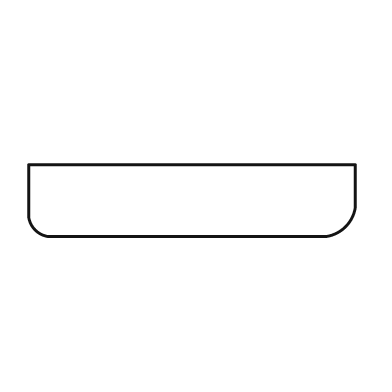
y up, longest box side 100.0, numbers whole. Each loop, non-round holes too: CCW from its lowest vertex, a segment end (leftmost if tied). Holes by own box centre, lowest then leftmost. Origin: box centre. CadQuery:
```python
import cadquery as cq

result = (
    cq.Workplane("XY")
    .moveTo(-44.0, -11.0)
    .lineTo(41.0, -11.0)
    .threePointArc((47.0, -8.0), (50.0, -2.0))
    .lineTo(50.0, 11.0)
    .lineTo(-50.0, 11.0)
    .lineTo(-50.0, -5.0)
    .threePointArc((-48.0, -9.0), (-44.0, -11.0))
    .close()
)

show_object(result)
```